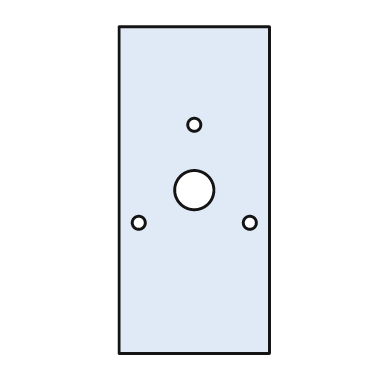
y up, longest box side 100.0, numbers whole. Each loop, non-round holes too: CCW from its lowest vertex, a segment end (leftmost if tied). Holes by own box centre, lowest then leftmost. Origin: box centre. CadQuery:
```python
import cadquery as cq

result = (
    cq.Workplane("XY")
    .moveTo(-23.0, -50.0)
    .lineTo(23.0, -50.0)
    .lineTo(23.0, 50.0)
    .lineTo(-23.0, 50.0)
    .close()
    .moveTo(-17.0, -10.0)
    .circle(2.0)
    .moveTo(17.0, -10.0)
    .circle(2.0)
    .moveTo(0.0, 0.0)
    .circle(6.0)
    .moveTo(0.0, 20.0)
    .circle(2.0)
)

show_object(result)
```